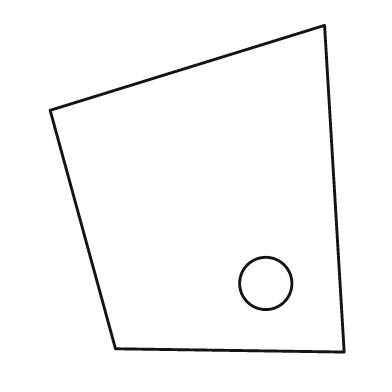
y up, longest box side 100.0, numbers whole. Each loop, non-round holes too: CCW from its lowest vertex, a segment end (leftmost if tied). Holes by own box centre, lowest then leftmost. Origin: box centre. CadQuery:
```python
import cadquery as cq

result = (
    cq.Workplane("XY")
    .moveTo(45.0, -50.0)
    .lineTo(39.0, 50.0)
    .lineTo(-45.0, 24.0)
    .lineTo(-25.0, -49.0)
    .close()
    .moveTo(21.0, -29.0)
    .circle(8.0)
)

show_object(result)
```